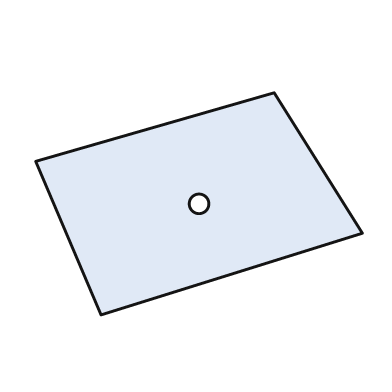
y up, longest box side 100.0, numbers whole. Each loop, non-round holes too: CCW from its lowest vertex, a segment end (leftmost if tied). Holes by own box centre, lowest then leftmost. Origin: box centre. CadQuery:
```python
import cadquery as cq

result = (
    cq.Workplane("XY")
    .moveTo(-30.0, -34.0)
    .lineTo(50.0, -9.0)
    .lineTo(23.0, 34.0)
    .lineTo(-50.0, 13.0)
    .close()
    .moveTo(0.0, 0.0)
    .circle(3.0)
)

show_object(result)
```